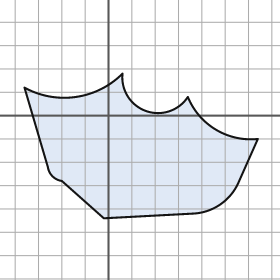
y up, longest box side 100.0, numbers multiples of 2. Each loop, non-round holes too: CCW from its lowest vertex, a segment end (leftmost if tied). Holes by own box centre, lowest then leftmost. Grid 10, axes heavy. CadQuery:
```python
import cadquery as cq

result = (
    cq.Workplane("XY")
    .moveTo(-2.0, -44.0)
    .lineTo(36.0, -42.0)
    .threePointArc((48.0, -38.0), (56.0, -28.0))
    .lineTo(64.0, -10.0)
    .threePointArc((46.0, -6.0), (34.0, 8.0))
    .threePointArc((16.0, 2.0), (6.0, 18.0))
    .threePointArc((-14.0, 8.0), (-36.0, 12.0))
    .lineTo(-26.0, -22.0)
    .threePointArc((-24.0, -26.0), (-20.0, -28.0))
    .close()
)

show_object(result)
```